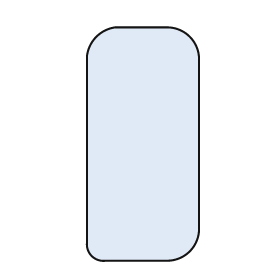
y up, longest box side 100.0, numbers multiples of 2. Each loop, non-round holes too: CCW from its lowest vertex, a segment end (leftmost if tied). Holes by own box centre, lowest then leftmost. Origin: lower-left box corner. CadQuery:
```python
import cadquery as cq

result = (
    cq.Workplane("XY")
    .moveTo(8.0, 0.0)
    .lineTo(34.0, 0.0)
    .threePointArc((44.0, 4.0), (48.0, 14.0))
    .lineTo(48.0, 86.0)
    .threePointArc((44.0, 96.0), (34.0, 100.0))
    .lineTo(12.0, 100.0)
    .threePointArc((4.0, 96.0), (0.0, 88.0))
    .lineTo(0.0, 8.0)
    .threePointArc((2.0, 2.0), (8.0, 0.0))
    .close()
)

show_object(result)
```